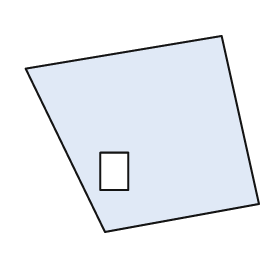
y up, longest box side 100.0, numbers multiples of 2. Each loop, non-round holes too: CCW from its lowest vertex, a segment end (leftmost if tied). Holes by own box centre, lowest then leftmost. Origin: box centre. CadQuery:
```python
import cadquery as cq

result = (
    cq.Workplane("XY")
    .moveTo(-16.0, -42.0)
    .lineTo(50.0, -30.0)
    .lineTo(34.0, 42.0)
    .lineTo(-50.0, 28.0)
    .close()
    .moveTo(-18.0, -24.0)
    .lineTo(-6.0, -24.0)
    .lineTo(-6.0, -8.0)
    .lineTo(-18.0, -8.0)
    .close()
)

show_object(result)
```